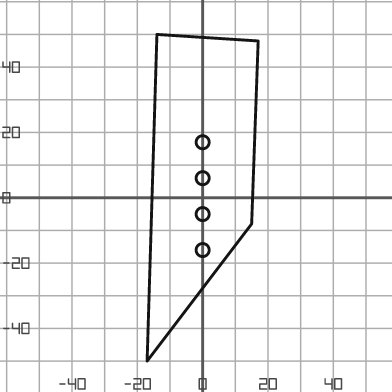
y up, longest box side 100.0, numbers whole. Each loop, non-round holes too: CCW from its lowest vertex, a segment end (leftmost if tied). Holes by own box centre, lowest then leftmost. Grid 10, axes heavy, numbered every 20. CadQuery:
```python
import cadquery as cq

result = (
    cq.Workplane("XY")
    .moveTo(-17.0, -50.0)
    .lineTo(15.0, -8.0)
    .lineTo(17.0, 48.0)
    .lineTo(-14.0, 50.0)
    .close()
    .moveTo(0.0, -16.0)
    .circle(2.0)
    .moveTo(0.0, -5.0)
    .circle(2.0)
    .moveTo(0.0, 6.0)
    .circle(2.0)
    .moveTo(0.0, 17.0)
    .circle(2.0)
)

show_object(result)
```